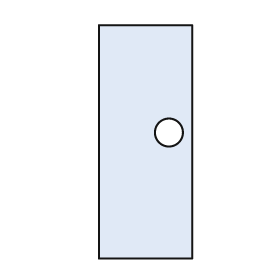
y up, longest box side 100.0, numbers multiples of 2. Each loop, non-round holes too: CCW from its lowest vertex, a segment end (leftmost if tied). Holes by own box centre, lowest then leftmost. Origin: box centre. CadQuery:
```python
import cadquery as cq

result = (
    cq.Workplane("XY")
    .moveTo(-20.0, -50.0)
    .lineTo(20.0, -50.0)
    .lineTo(20.0, 50.0)
    .lineTo(-20.0, 50.0)
    .close()
    .moveTo(10.0, 4.0)
    .circle(6.0)
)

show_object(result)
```